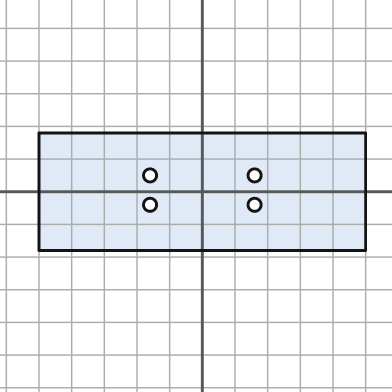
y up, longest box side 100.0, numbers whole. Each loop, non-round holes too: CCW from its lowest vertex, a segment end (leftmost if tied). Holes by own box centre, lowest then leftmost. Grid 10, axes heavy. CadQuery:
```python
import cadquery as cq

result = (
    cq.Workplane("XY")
    .moveTo(-50.0, -18.0)
    .lineTo(50.0, -18.0)
    .lineTo(50.0, 18.0)
    .lineTo(-50.0, 18.0)
    .close()
    .moveTo(-16.0, -4.0)
    .circle(2.0)
    .moveTo(16.0, -4.0)
    .circle(2.0)
    .moveTo(-16.0, 5.0)
    .circle(2.0)
    .moveTo(16.0, 5.0)
    .circle(2.0)
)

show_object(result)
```